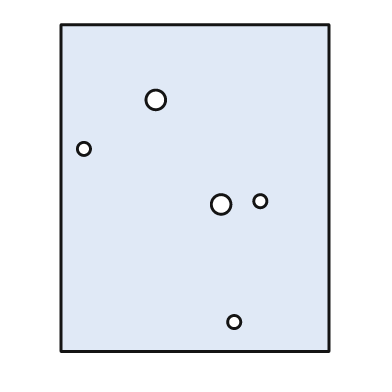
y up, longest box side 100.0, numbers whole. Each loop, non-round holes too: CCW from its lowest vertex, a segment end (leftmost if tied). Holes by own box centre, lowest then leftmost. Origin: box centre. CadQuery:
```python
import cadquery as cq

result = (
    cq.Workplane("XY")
    .moveTo(-41.0, -50.0)
    .lineTo(41.0, -50.0)
    .lineTo(41.0, 50.0)
    .lineTo(-41.0, 50.0)
    .close()
    .moveTo(12.0, -41.0)
    .circle(2.0)
    .moveTo(8.0, -5.0)
    .circle(3.0)
    .moveTo(20.0, -4.0)
    .circle(2.0)
    .moveTo(-34.0, 12.0)
    .circle(2.0)
    .moveTo(-12.0, 27.0)
    .circle(3.0)
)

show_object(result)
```